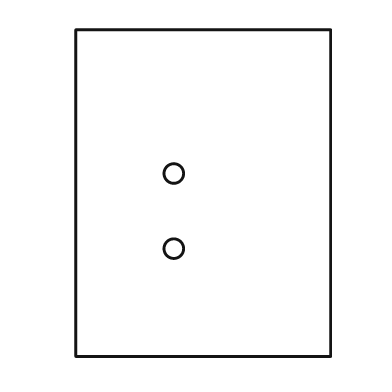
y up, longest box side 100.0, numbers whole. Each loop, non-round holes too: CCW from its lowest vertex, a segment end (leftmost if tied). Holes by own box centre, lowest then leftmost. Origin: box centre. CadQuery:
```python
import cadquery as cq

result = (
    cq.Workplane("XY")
    .moveTo(-39.0, -50.0)
    .lineTo(39.0, -50.0)
    .lineTo(39.0, 50.0)
    .lineTo(-39.0, 50.0)
    .close()
    .moveTo(-9.0, -17.0)
    .circle(3.0)
    .moveTo(-9.0, 6.0)
    .circle(3.0)
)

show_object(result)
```